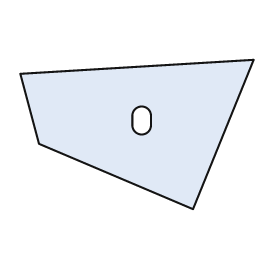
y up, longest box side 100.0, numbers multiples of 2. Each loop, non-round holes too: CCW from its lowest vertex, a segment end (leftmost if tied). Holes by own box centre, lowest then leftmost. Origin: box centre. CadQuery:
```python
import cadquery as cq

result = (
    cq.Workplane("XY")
    .moveTo(24.0, -32.0)
    .lineTo(50.0, 32.0)
    .lineTo(-50.0, 26.0)
    .lineTo(-42.0, -4.0)
    .close()
    .moveTo(-2.0, 4.0)
    .threePointArc((2.0, 0.0), (6.0, 4.0))
    .lineTo(6.0, 8.0)
    .threePointArc((2.0, 12.0), (-2.0, 8.0))
    .close()
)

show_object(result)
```